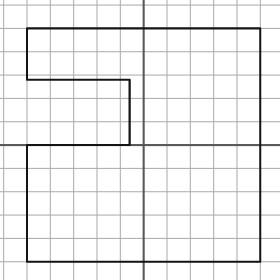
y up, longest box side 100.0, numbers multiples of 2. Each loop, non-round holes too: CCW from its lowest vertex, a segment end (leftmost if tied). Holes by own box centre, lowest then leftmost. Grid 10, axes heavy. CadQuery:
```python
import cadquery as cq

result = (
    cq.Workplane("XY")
    .moveTo(-50.0, -50.0)
    .lineTo(50.0, -50.0)
    .lineTo(50.0, 50.0)
    .lineTo(-50.0, 50.0)
    .lineTo(-50.0, 28.0)
    .lineTo(-6.0, 28.0)
    .lineTo(-6.0, 0.0)
    .lineTo(-50.0, 0.0)
    .close()
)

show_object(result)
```